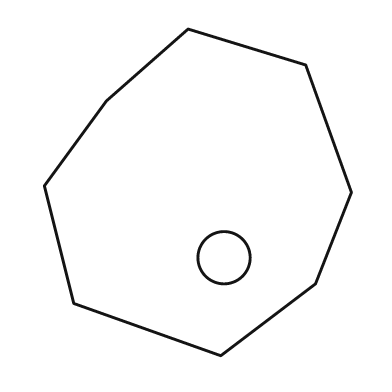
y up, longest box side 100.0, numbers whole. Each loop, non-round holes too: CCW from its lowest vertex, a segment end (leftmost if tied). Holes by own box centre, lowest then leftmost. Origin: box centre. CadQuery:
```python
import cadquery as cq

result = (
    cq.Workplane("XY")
    .moveTo(7.0, -50.0)
    .lineTo(36.0, -28.0)
    .lineTo(47.0, 0.0)
    .lineTo(33.0, 39.0)
    .lineTo(-3.0, 50.0)
    .lineTo(-28.0, 28.0)
    .lineTo(-47.0, 2.0)
    .lineTo(-38.0, -34.0)
    .close()
    .moveTo(8.0, -20.0)
    .circle(8.0)
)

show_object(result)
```